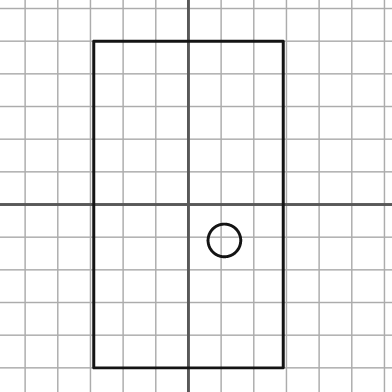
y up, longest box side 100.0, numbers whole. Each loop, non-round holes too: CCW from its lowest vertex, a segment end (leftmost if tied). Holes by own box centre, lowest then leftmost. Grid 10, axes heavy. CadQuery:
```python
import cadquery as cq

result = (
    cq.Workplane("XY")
    .moveTo(-29.0, -50.0)
    .lineTo(29.0, -50.0)
    .lineTo(29.0, 50.0)
    .lineTo(-29.0, 50.0)
    .close()
    .moveTo(11.0, -11.0)
    .circle(5.0)
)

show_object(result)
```